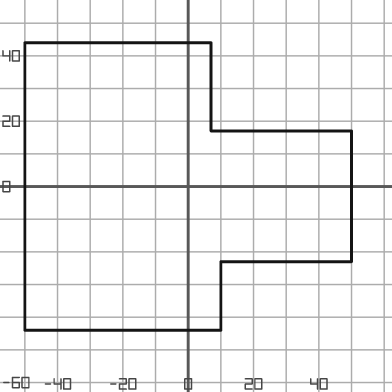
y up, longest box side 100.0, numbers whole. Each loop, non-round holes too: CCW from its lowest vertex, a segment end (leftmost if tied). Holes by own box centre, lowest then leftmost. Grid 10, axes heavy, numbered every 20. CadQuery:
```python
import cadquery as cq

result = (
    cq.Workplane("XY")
    .moveTo(-50.0, -44.0)
    .lineTo(10.0, -44.0)
    .lineTo(10.0, -23.0)
    .lineTo(50.0, -23.0)
    .lineTo(50.0, 17.0)
    .lineTo(7.0, 17.0)
    .lineTo(7.0, 44.0)
    .lineTo(-50.0, 44.0)
    .close()
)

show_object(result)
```